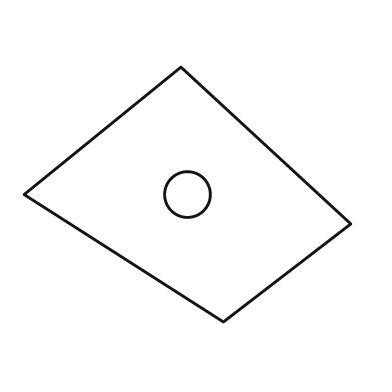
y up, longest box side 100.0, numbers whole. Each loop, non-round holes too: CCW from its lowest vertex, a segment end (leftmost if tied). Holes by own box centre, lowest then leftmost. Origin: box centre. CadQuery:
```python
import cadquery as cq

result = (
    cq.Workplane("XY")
    .moveTo(11.0, -39.0)
    .lineTo(50.0, -9.0)
    .lineTo(-2.0, 39.0)
    .lineTo(-50.0, 0.0)
    .close()
    .moveTo(0.0, 0.0)
    .circle(7.0)
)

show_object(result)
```